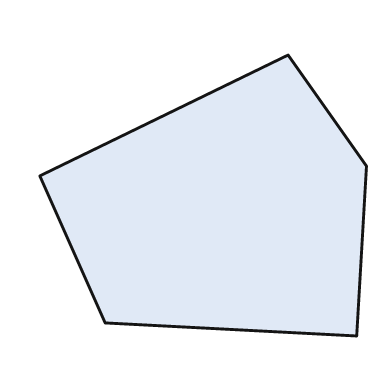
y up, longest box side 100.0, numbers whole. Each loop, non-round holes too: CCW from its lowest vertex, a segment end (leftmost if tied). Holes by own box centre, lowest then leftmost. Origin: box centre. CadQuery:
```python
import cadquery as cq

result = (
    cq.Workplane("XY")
    .moveTo(47.0, -43.0)
    .lineTo(50.0, 9.0)
    .lineTo(26.0, 43.0)
    .lineTo(-50.0, 6.0)
    .lineTo(-30.0, -39.0)
    .close()
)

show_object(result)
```